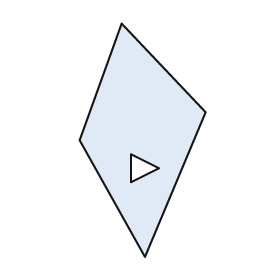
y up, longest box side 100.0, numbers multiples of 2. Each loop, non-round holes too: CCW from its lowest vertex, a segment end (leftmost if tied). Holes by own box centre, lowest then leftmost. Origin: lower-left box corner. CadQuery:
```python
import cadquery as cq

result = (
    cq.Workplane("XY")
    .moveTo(28.0, 0.0)
    .lineTo(54.0, 62.0)
    .lineTo(18.0, 100.0)
    .lineTo(0.0, 50.0)
    .close()
    .moveTo(22.0, 32.0)
    .lineTo(34.0, 38.0)
    .lineTo(22.0, 44.0)
    .close()
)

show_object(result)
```